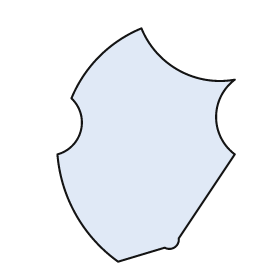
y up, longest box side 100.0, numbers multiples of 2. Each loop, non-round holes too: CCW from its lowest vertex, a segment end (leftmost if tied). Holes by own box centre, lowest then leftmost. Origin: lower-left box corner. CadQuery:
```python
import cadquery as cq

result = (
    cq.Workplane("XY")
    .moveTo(26.0, 0.0)
    .lineTo(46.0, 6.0)
    .threePointArc((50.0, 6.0), (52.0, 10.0))
    .lineTo(76.0, 46.0)
    .threePointArc((68.0, 62.0), (76.0, 78.0))
    .threePointArc((52.0, 82.0), (36.0, 100.0))
    .threePointArc((18.0, 88.0), (6.0, 70.0))
    .threePointArc((10.0, 56.0), (0.0, 46.0))
    .threePointArc((8.0, 20.0), (26.0, 0.0))
    .close()
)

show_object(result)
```